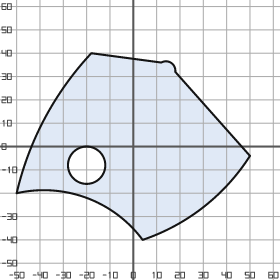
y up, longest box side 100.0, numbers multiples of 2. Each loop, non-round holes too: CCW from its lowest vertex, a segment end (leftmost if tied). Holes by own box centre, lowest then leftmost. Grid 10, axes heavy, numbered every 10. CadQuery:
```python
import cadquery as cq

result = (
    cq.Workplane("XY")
    .moveTo(4.0, -40.0)
    .threePointArc((30.0, -26.0), (50.0, -4.0))
    .lineTo(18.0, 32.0)
    .threePointArc((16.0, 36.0), (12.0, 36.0))
    .lineTo(-18.0, 40.0)
    .threePointArc((-38.0, 12.0), (-50.0, -20.0))
    .threePointArc((-20.0, -22.0), (4.0, -40.0))
    .close()
    .moveTo(-20.0, -8.0)
    .circle(8.0)
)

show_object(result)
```